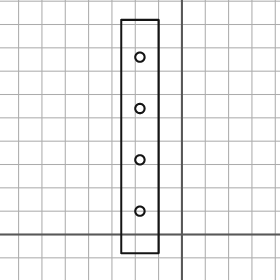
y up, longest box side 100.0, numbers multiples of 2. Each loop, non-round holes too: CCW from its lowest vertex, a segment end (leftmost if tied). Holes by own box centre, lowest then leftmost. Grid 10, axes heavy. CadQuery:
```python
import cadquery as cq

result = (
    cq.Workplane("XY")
    .moveTo(-26.0, -8.0)
    .lineTo(-10.0, -8.0)
    .lineTo(-10.0, 92.0)
    .lineTo(-26.0, 92.0)
    .close()
    .moveTo(-18.0, 10.0)
    .circle(2.0)
    .moveTo(-18.0, 32.0)
    .circle(2.0)
    .moveTo(-18.0, 54.0)
    .circle(2.0)
    .moveTo(-18.0, 76.0)
    .circle(2.0)
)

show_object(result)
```